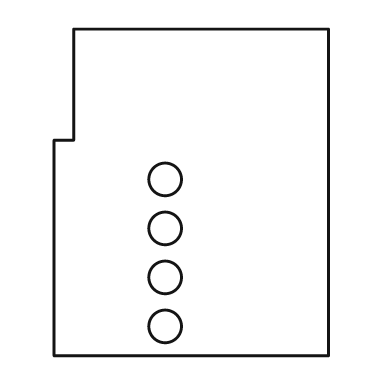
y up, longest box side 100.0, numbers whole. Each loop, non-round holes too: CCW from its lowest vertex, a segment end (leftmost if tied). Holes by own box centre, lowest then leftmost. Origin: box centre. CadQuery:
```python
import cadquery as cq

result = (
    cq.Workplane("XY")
    .moveTo(-42.0, -50.0)
    .lineTo(42.0, -50.0)
    .lineTo(42.0, 50.0)
    .lineTo(-36.0, 50.0)
    .lineTo(-36.0, 16.0)
    .lineTo(-42.0, 16.0)
    .close()
    .moveTo(-8.0, -41.0)
    .circle(5.0)
    .moveTo(-8.0, -26.0)
    .circle(5.0)
    .moveTo(-8.0, -11.0)
    .circle(5.0)
    .moveTo(-8.0, 4.0)
    .circle(5.0)
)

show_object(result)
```